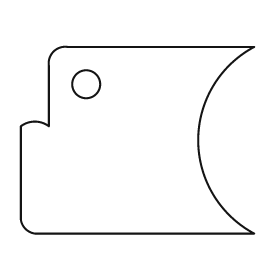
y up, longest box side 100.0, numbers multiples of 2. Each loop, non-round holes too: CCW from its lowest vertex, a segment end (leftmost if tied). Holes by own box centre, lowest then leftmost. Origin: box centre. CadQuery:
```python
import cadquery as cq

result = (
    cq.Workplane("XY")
    .moveTo(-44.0, -40.0)
    .lineTo(50.0, -40.0)
    .threePointArc((26.0, 0.0), (50.0, 40.0))
    .lineTo(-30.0, 40.0)
    .threePointArc((-36.0, 38.0), (-38.0, 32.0))
    .lineTo(-38.0, 6.0)
    .threePointArc((-44.0, 8.0), (-50.0, 6.0))
    .lineTo(-50.0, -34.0)
    .threePointArc((-48.0, -38.0), (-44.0, -40.0))
    .close()
    .moveTo(-22.0, 24.0)
    .circle(6.0)
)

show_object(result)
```